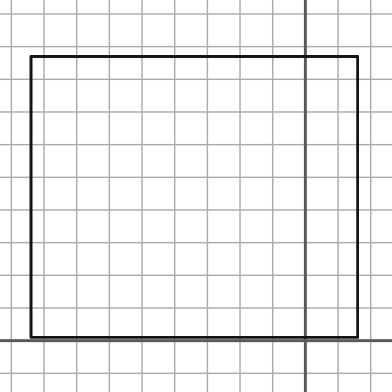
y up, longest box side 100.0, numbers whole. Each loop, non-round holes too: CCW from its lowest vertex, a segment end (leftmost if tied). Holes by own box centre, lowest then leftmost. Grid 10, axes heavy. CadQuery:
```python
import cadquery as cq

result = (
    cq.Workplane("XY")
    .moveTo(-84.0, 1.0)
    .lineTo(16.0, 1.0)
    .lineTo(16.0, 87.0)
    .lineTo(-84.0, 87.0)
    .close()
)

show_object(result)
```